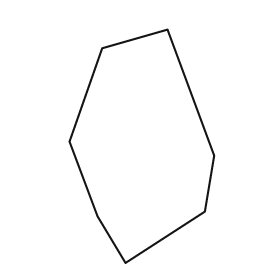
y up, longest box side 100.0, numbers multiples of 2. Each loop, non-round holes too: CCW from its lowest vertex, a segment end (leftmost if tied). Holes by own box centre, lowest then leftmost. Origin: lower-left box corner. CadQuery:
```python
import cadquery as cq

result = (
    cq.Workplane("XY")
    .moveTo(24.0, 0.0)
    .lineTo(58.0, 22.0)
    .lineTo(62.0, 46.0)
    .lineTo(42.0, 100.0)
    .lineTo(14.0, 92.0)
    .lineTo(0.0, 52.0)
    .lineTo(12.0, 20.0)
    .close()
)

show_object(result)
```